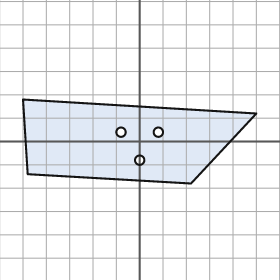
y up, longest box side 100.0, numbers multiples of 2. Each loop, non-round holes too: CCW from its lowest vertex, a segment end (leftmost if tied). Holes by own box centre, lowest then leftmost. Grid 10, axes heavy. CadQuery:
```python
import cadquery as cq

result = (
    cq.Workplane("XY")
    .moveTo(22.0, -18.0)
    .lineTo(50.0, 12.0)
    .lineTo(-50.0, 18.0)
    .lineTo(-48.0, -14.0)
    .close()
    .moveTo(0.0, -8.0)
    .circle(2.0)
    .moveTo(-8.0, 4.0)
    .circle(2.0)
    .moveTo(8.0, 4.0)
    .circle(2.0)
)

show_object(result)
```